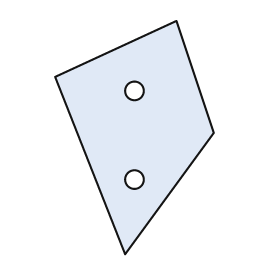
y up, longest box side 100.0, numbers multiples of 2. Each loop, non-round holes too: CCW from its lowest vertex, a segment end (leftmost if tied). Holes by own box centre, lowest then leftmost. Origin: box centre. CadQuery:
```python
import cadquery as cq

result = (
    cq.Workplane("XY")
    .moveTo(-4.0, -50.0)
    .lineTo(34.0, 2.0)
    .lineTo(18.0, 50.0)
    .lineTo(-34.0, 26.0)
    .close()
    .moveTo(0.0, -18.0)
    .circle(4.0)
    .moveTo(0.0, 20.0)
    .circle(4.0)
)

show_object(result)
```